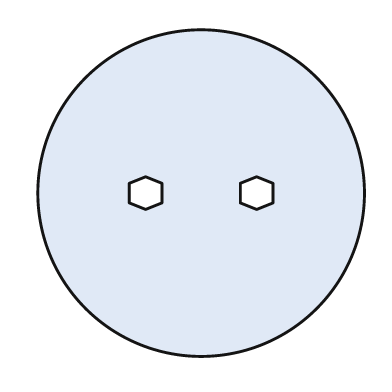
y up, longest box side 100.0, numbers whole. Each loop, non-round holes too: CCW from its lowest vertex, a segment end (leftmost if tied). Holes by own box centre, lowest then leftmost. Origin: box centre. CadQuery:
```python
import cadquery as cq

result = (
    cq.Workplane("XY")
    .moveTo(0.0, 0.0)
    .circle(50.0)
    .moveTo(-17.0, -5.0)
    .lineTo(-12.0, -3.0)
    .lineTo(-12.0, 3.0)
    .lineTo(-17.0, 5.0)
    .lineTo(-22.0, 3.0)
    .lineTo(-22.0, -3.0)
    .close()
    .moveTo(17.0, -5.0)
    .lineTo(22.0, -3.0)
    .lineTo(22.0, 3.0)
    .lineTo(17.0, 5.0)
    .lineTo(12.0, 3.0)
    .lineTo(12.0, -3.0)
    .close()
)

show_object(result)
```